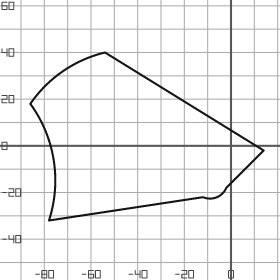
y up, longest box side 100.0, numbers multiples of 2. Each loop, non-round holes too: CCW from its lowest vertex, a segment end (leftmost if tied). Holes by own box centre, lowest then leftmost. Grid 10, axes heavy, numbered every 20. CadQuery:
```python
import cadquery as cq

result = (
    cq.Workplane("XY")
    .moveTo(-78.0, -32.0)
    .lineTo(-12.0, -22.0)
    .threePointArc((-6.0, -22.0), (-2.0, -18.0))
    .lineTo(14.0, -2.0)
    .lineTo(-54.0, 40.0)
    .threePointArc((-72.0, 32.0), (-86.0, 18.0))
    .threePointArc((-76.0, -6.0), (-78.0, -32.0))
    .close()
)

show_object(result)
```